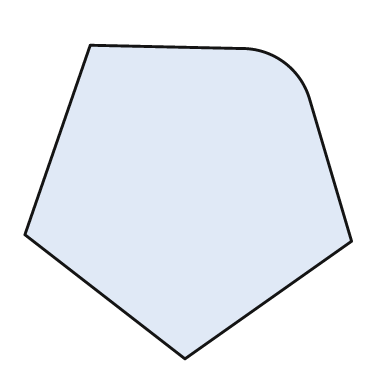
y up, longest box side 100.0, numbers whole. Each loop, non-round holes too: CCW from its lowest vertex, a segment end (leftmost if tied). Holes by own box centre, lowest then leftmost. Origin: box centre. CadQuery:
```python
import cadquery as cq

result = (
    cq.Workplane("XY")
    .moveTo(-1.0, -48.0)
    .lineTo(50.0, -12.0)
    .lineTo(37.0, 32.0)
    .threePointArc((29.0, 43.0), (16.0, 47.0))
    .lineTo(-30.0, 48.0)
    .lineTo(-50.0, -10.0)
    .close()
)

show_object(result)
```